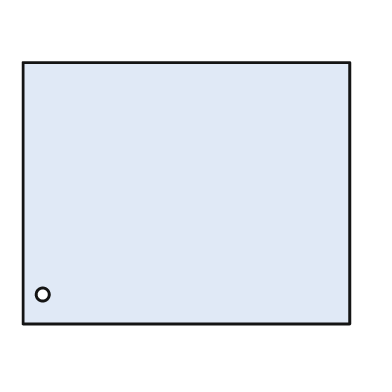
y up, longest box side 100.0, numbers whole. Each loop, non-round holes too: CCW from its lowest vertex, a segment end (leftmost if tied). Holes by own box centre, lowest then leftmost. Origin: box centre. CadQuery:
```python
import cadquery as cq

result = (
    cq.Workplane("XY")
    .moveTo(-50.0, -40.0)
    .lineTo(50.0, -40.0)
    .lineTo(50.0, 40.0)
    .lineTo(-50.0, 40.0)
    .close()
    .moveTo(-44.0, -31.0)
    .circle(2.0)
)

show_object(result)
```